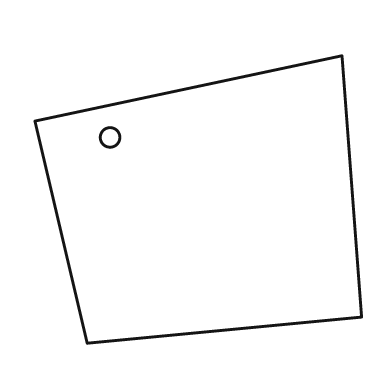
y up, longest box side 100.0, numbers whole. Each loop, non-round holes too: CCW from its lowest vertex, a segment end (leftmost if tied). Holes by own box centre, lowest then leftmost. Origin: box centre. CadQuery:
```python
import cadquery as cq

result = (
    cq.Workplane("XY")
    .moveTo(-34.0, -44.0)
    .lineTo(50.0, -36.0)
    .lineTo(44.0, 44.0)
    .lineTo(-50.0, 24.0)
    .close()
    .moveTo(-27.0, 19.0)
    .circle(3.0)
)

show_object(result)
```